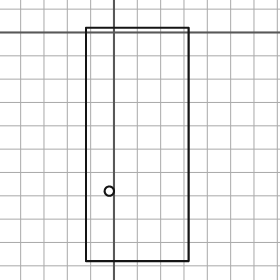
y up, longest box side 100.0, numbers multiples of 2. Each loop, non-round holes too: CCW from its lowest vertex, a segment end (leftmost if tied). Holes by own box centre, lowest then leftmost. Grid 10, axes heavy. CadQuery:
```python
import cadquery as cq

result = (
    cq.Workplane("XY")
    .moveTo(-12.0, -98.0)
    .lineTo(32.0, -98.0)
    .lineTo(32.0, 2.0)
    .lineTo(-12.0, 2.0)
    .close()
    .moveTo(-2.0, -68.0)
    .circle(2.0)
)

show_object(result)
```